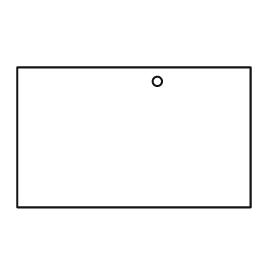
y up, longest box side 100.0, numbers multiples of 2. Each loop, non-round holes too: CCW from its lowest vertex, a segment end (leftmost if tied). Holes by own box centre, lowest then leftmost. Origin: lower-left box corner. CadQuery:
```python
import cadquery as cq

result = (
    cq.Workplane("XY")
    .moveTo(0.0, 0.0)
    .lineTo(100.0, 0.0)
    .lineTo(100.0, 60.0)
    .lineTo(0.0, 60.0)
    .close()
    .moveTo(60.0, 54.0)
    .circle(2.0)
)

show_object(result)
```